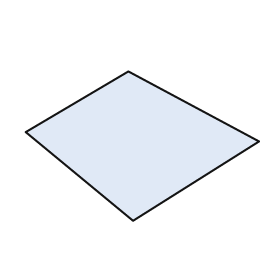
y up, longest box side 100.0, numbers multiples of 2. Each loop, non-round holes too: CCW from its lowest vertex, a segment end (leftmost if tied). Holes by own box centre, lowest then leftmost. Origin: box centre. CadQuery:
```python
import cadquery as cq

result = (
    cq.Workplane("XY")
    .moveTo(-4.0, -32.0)
    .lineTo(50.0, 2.0)
    .lineTo(-6.0, 32.0)
    .lineTo(-50.0, 6.0)
    .close()
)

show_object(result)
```